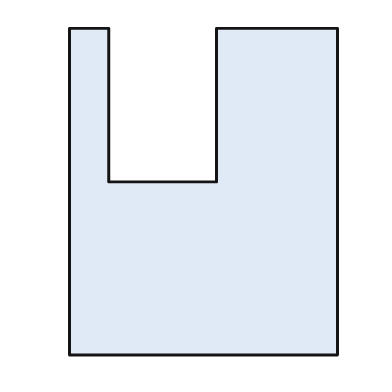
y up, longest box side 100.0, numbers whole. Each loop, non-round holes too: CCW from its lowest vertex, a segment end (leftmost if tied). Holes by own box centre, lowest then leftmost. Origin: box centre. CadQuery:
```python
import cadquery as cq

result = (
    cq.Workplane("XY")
    .moveTo(-41.0, -50.0)
    .lineTo(41.0, -50.0)
    .lineTo(41.0, 50.0)
    .lineTo(4.0, 50.0)
    .lineTo(4.0, 3.0)
    .lineTo(-29.0, 3.0)
    .lineTo(-29.0, 50.0)
    .lineTo(-41.0, 50.0)
    .close()
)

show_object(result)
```